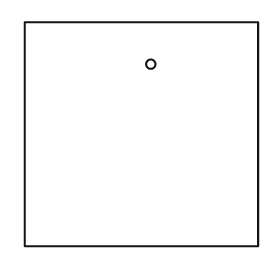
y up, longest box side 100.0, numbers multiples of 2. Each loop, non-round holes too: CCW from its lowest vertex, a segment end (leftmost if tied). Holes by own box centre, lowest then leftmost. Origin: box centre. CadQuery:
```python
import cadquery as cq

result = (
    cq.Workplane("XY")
    .moveTo(-50.0, -48.0)
    .lineTo(50.0, -48.0)
    .lineTo(50.0, 48.0)
    .lineTo(-50.0, 48.0)
    .close()
    .moveTo(4.0, 30.0)
    .circle(2.0)
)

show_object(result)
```